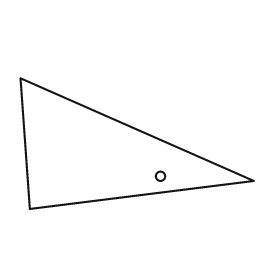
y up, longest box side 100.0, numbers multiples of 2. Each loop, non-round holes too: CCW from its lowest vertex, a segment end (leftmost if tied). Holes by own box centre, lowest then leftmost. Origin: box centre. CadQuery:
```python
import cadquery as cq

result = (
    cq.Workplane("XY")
    .moveTo(-46.0, -28.0)
    .lineTo(50.0, -16.0)
    .lineTo(-50.0, 28.0)
    .close()
    .moveTo(10.0, -14.0)
    .circle(2.0)
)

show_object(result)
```